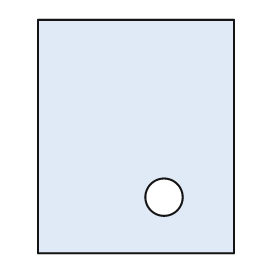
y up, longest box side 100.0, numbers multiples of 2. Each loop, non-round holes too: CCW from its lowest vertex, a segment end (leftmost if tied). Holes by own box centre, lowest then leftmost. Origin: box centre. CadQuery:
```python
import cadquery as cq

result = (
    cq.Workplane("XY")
    .moveTo(-42.0, -50.0)
    .lineTo(42.0, -50.0)
    .lineTo(42.0, 50.0)
    .lineTo(-42.0, 50.0)
    .close()
    .moveTo(12.0, -26.0)
    .circle(8.0)
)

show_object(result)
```